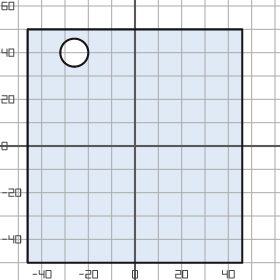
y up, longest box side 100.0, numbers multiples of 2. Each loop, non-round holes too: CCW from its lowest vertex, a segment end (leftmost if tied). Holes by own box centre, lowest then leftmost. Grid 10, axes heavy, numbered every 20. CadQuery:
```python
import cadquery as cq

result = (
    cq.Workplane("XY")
    .moveTo(-46.0, -50.0)
    .lineTo(46.0, -50.0)
    .lineTo(46.0, 50.0)
    .lineTo(-46.0, 50.0)
    .close()
    .moveTo(-26.0, 40.0)
    .circle(6.0)
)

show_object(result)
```